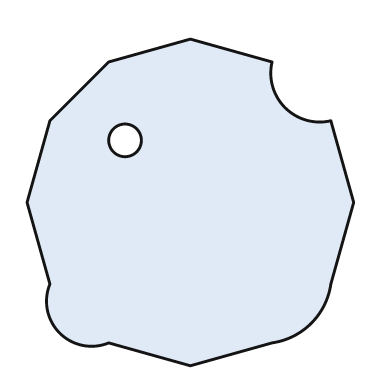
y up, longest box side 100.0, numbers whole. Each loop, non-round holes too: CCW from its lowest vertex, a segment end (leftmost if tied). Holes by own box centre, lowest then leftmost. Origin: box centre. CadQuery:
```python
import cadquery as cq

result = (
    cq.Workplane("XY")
    .moveTo(0.0, -50.0)
    .lineTo(25.0, -43.0)
    .threePointArc((37.0, -37.0), (43.0, -25.0))
    .lineTo(50.0, 0.0)
    .lineTo(43.0, 25.0)
    .threePointArc((29.0, 29.0), (25.0, 43.0))
    .lineTo(0.0, 50.0)
    .lineTo(-25.0, 43.0)
    .lineTo(-43.0, 25.0)
    .lineTo(-50.0, 0.0)
    .lineTo(-43.0, -25.0)
    .threePointArc((-40.0, -40.0), (-25.0, -43.0))
    .close()
    .moveTo(-20.0, 19.0)
    .circle(5.0)
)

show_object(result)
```